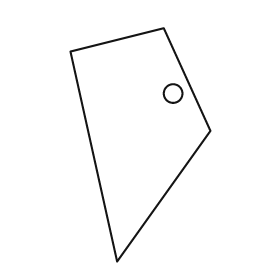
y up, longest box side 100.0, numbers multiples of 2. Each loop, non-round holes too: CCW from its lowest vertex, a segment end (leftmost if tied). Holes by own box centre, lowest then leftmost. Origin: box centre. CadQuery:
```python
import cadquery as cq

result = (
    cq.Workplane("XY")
    .moveTo(-10.0, -50.0)
    .lineTo(30.0, 6.0)
    .lineTo(10.0, 50.0)
    .lineTo(-30.0, 40.0)
    .close()
    .moveTo(14.0, 22.0)
    .circle(4.0)
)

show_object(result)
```